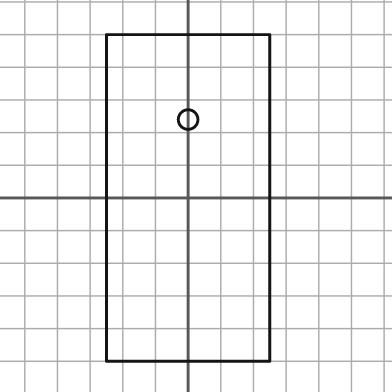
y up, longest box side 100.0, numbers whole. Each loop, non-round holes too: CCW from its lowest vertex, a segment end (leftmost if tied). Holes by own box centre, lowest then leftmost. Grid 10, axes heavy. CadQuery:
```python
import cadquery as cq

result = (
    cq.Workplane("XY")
    .moveTo(-25.0, -50.0)
    .lineTo(25.0, -50.0)
    .lineTo(25.0, 50.0)
    .lineTo(-25.0, 50.0)
    .close()
    .moveTo(0.0, 24.0)
    .circle(3.0)
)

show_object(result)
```